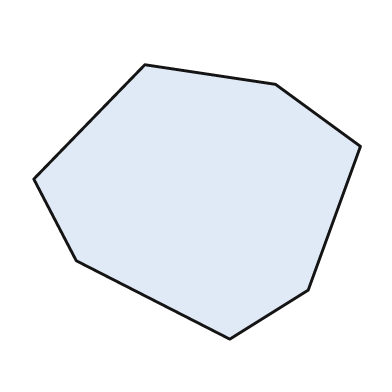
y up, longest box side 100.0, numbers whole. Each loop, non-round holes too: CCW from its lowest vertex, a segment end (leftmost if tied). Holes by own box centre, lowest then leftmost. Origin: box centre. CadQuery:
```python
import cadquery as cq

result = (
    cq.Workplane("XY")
    .moveTo(10.0, -42.0)
    .lineTo(34.0, -27.0)
    .lineTo(50.0, 17.0)
    .lineTo(24.0, 36.0)
    .lineTo(-16.0, 42.0)
    .lineTo(-50.0, 7.0)
    .lineTo(-37.0, -18.0)
    .close()
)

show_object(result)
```